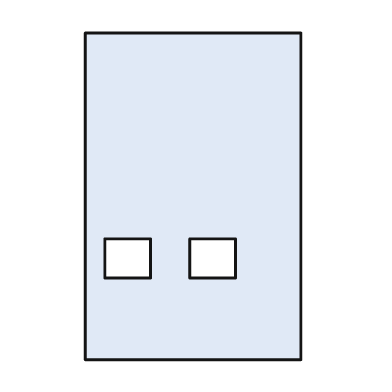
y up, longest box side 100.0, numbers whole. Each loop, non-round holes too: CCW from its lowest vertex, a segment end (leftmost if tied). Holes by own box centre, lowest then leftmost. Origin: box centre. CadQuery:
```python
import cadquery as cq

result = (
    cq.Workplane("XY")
    .moveTo(-33.0, -50.0)
    .lineTo(33.0, -50.0)
    .lineTo(33.0, 50.0)
    .lineTo(-33.0, 50.0)
    .close()
    .moveTo(-27.0, -25.0)
    .lineTo(-13.0, -25.0)
    .lineTo(-13.0, -13.0)
    .lineTo(-27.0, -13.0)
    .close()
    .moveTo(-1.0, -25.0)
    .lineTo(13.0, -25.0)
    .lineTo(13.0, -13.0)
    .lineTo(-1.0, -13.0)
    .close()
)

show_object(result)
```